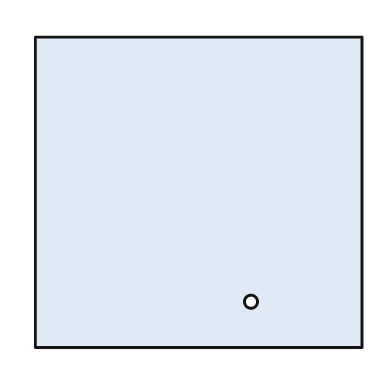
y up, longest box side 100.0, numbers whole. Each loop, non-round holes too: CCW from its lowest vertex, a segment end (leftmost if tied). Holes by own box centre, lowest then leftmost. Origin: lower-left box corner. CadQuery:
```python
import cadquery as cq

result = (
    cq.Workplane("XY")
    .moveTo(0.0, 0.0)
    .lineTo(100.0, 0.0)
    .lineTo(100.0, 95.0)
    .lineTo(0.0, 95.0)
    .close()
    .moveTo(66.0, 14.0)
    .circle(2.0)
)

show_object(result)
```